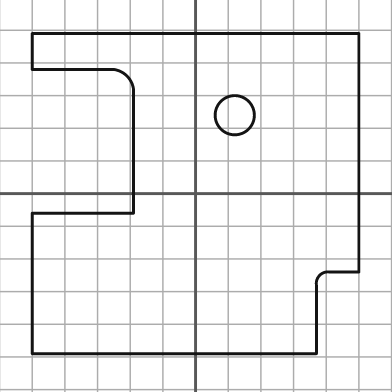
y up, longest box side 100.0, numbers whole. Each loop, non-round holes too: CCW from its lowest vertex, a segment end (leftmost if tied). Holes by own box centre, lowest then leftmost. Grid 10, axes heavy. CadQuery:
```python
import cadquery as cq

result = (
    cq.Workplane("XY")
    .moveTo(-50.0, -49.0)
    .lineTo(37.0, -49.0)
    .lineTo(37.0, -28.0)
    .threePointArc((38.0, -25.0), (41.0, -24.0))
    .lineTo(50.0, -24.0)
    .lineTo(50.0, 49.0)
    .lineTo(-50.0, 49.0)
    .lineTo(-50.0, 38.0)
    .lineTo(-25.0, 38.0)
    .threePointArc((-21.0, 36.0), (-19.0, 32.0))
    .lineTo(-19.0, -6.0)
    .lineTo(-50.0, -6.0)
    .close()
    .moveTo(12.0, 24.0)
    .circle(6.0)
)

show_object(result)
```